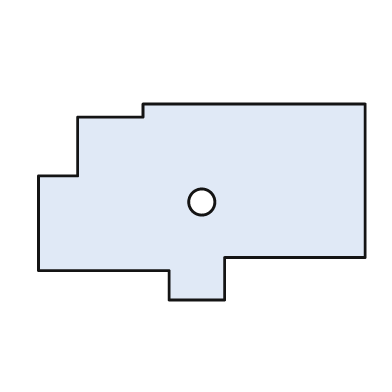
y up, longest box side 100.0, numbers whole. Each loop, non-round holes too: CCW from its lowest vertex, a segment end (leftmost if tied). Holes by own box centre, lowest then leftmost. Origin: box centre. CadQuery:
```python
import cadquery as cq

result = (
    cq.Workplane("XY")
    .moveTo(-10.0, -30.0)
    .lineTo(7.0, -30.0)
    .lineTo(7.0, -17.0)
    .lineTo(50.0, -17.0)
    .lineTo(50.0, 30.0)
    .lineTo(-18.0, 30.0)
    .lineTo(-18.0, 26.0)
    .lineTo(-38.0, 26.0)
    .lineTo(-38.0, 8.0)
    .lineTo(-50.0, 8.0)
    .lineTo(-50.0, -21.0)
    .lineTo(-10.0, -21.0)
    .close()
    .moveTo(0.0, 0.0)
    .circle(4.0)
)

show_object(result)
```